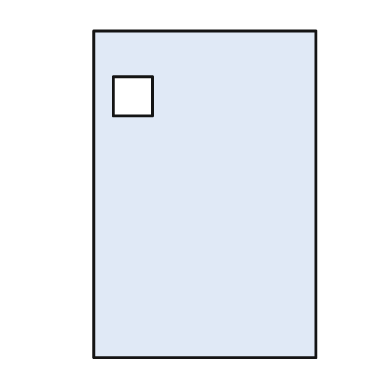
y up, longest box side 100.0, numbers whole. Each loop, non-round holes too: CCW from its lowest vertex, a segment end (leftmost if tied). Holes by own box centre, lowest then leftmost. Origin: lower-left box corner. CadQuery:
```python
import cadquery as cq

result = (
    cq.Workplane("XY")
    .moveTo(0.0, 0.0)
    .lineTo(68.0, 0.0)
    .lineTo(68.0, 100.0)
    .lineTo(0.0, 100.0)
    .close()
    .moveTo(6.0, 74.0)
    .lineTo(18.0, 74.0)
    .lineTo(18.0, 86.0)
    .lineTo(6.0, 86.0)
    .close()
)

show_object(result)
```